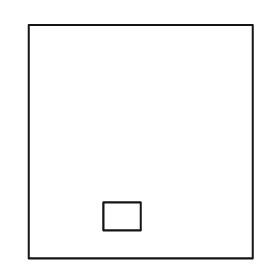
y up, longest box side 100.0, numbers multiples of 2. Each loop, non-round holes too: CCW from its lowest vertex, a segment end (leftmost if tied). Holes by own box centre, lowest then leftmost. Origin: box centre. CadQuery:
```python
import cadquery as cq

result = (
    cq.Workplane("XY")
    .moveTo(-48.0, -50.0)
    .lineTo(48.0, -50.0)
    .lineTo(48.0, 50.0)
    .lineTo(-48.0, 50.0)
    .close()
    .moveTo(-16.0, -38.0)
    .lineTo(0.0, -38.0)
    .lineTo(0.0, -26.0)
    .lineTo(-16.0, -26.0)
    .close()
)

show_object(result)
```